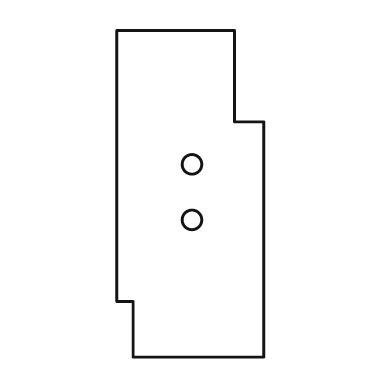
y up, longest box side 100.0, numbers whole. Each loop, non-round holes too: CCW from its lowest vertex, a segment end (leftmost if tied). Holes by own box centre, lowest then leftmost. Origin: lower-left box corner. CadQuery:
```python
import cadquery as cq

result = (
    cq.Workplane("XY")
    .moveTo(5.0, 0.0)
    .lineTo(45.0, 0.0)
    .lineTo(45.0, 72.0)
    .lineTo(36.0, 72.0)
    .lineTo(36.0, 100.0)
    .lineTo(0.0, 100.0)
    .lineTo(0.0, 17.0)
    .lineTo(5.0, 17.0)
    .close()
    .moveTo(23.0, 42.0)
    .circle(3.0)
    .moveTo(23.0, 59.0)
    .circle(3.0)
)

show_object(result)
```